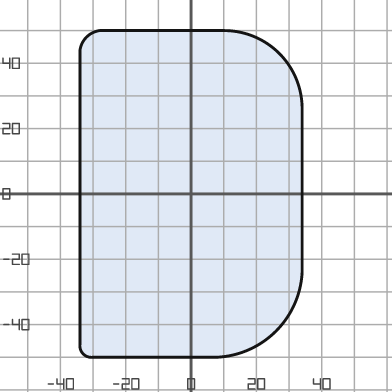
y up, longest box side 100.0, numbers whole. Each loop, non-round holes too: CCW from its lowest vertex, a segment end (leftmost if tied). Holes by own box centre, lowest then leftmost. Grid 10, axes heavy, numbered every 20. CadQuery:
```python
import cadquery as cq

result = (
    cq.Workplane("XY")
    .moveTo(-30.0, -50.0)
    .lineTo(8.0, -50.0)
    .threePointArc((26.0, -42.0), (34.0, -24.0))
    .lineTo(34.0, 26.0)
    .threePointArc((27.0, 43.0), (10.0, 50.0))
    .lineTo(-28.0, 50.0)
    .threePointArc((-32.0, 48.0), (-34.0, 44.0))
    .lineTo(-34.0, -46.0)
    .threePointArc((-33.0, -49.0), (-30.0, -50.0))
    .close()
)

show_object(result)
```